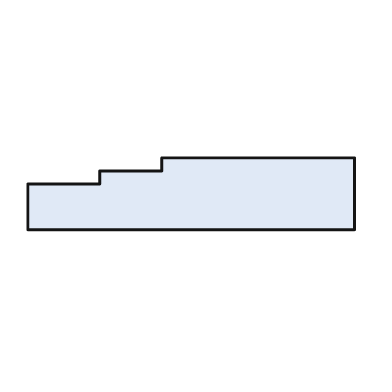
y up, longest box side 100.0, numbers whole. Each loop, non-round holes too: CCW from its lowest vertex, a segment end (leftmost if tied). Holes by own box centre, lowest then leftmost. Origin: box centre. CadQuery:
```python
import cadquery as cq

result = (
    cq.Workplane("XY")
    .moveTo(-50.0, -11.0)
    .lineTo(50.0, -11.0)
    .lineTo(50.0, 11.0)
    .lineTo(-9.0, 11.0)
    .lineTo(-9.0, 7.0)
    .lineTo(-28.0, 7.0)
    .lineTo(-28.0, 3.0)
    .lineTo(-50.0, 3.0)
    .close()
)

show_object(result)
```